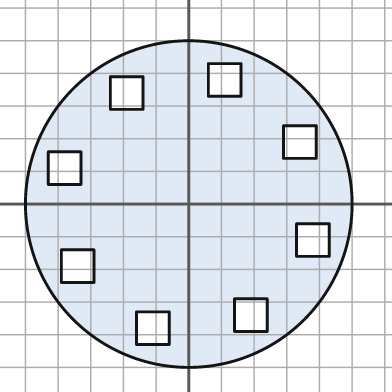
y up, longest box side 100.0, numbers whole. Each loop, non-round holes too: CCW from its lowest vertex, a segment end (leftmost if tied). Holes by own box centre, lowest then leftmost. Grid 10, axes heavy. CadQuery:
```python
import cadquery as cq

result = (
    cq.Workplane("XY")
    .moveTo(0.0, 0.0)
    .circle(50.0)
    .moveTo(-16.0, -43.0)
    .lineTo(-6.0, -43.0)
    .lineTo(-6.0, -33.0)
    .lineTo(-16.0, -33.0)
    .close()
    .moveTo(14.0, -39.0)
    .lineTo(24.0, -39.0)
    .lineTo(24.0, -29.0)
    .lineTo(14.0, -29.0)
    .close()
    .moveTo(-39.0, -24.0)
    .lineTo(-29.0, -24.0)
    .lineTo(-29.0, -14.0)
    .lineTo(-39.0, -14.0)
    .close()
    .moveTo(33.0, -16.0)
    .lineTo(43.0, -16.0)
    .lineTo(43.0, -6.0)
    .lineTo(33.0, -6.0)
    .close()
    .moveTo(-43.0, 6.0)
    .lineTo(-33.0, 6.0)
    .lineTo(-33.0, 16.0)
    .lineTo(-43.0, 16.0)
    .close()
    .moveTo(29.0, 14.0)
    .lineTo(39.0, 14.0)
    .lineTo(39.0, 24.0)
    .lineTo(29.0, 24.0)
    .close()
    .moveTo(-24.0, 29.0)
    .lineTo(-14.0, 29.0)
    .lineTo(-14.0, 39.0)
    .lineTo(-24.0, 39.0)
    .close()
    .moveTo(6.0, 33.0)
    .lineTo(16.0, 33.0)
    .lineTo(16.0, 43.0)
    .lineTo(6.0, 43.0)
    .close()
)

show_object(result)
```